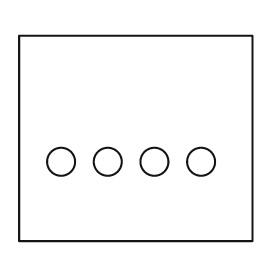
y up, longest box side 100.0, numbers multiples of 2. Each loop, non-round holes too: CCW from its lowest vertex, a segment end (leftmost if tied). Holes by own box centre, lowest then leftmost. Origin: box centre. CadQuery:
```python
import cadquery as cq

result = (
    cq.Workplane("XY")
    .moveTo(-50.0, -44.0)
    .lineTo(50.0, -44.0)
    .lineTo(50.0, 44.0)
    .lineTo(-50.0, 44.0)
    .close()
    .moveTo(-32.0, -10.0)
    .circle(6.0)
    .moveTo(-12.0, -10.0)
    .circle(6.0)
    .moveTo(8.0, -10.0)
    .circle(6.0)
    .moveTo(28.0, -10.0)
    .circle(6.0)
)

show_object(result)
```